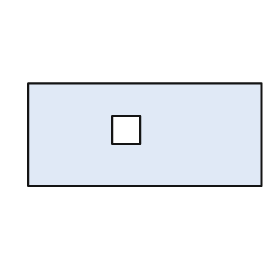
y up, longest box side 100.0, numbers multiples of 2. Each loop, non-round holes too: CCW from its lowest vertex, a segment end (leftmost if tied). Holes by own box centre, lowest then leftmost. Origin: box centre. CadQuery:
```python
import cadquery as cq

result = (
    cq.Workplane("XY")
    .moveTo(-50.0, -22.0)
    .lineTo(50.0, -22.0)
    .lineTo(50.0, 22.0)
    .lineTo(-50.0, 22.0)
    .close()
    .moveTo(-14.0, -4.0)
    .lineTo(-2.0, -4.0)
    .lineTo(-2.0, 8.0)
    .lineTo(-14.0, 8.0)
    .close()
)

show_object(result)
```